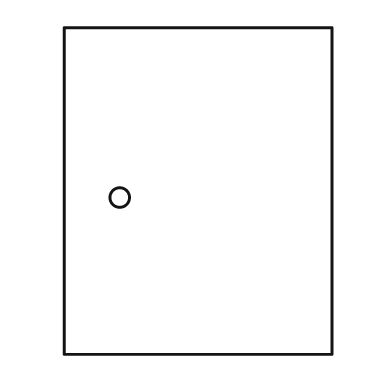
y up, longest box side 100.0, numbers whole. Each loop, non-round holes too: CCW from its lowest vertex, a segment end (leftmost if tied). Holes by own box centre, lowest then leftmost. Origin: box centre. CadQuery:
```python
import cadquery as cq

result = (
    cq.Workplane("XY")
    .moveTo(-41.0, -50.0)
    .lineTo(41.0, -50.0)
    .lineTo(41.0, 50.0)
    .lineTo(-41.0, 50.0)
    .close()
    .moveTo(-24.0, -2.0)
    .circle(3.0)
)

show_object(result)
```